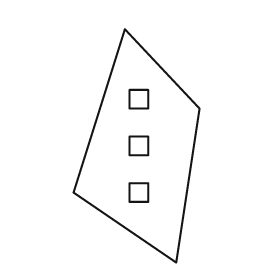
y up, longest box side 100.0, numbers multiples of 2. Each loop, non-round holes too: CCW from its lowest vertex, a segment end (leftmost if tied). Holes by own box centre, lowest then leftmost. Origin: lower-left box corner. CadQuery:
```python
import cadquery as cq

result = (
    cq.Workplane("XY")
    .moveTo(44.0, 0.0)
    .lineTo(54.0, 66.0)
    .lineTo(22.0, 100.0)
    .lineTo(0.0, 30.0)
    .close()
    .moveTo(24.0, 26.0)
    .lineTo(32.0, 26.0)
    .lineTo(32.0, 34.0)
    .lineTo(24.0, 34.0)
    .close()
    .moveTo(24.0, 46.0)
    .lineTo(32.0, 46.0)
    .lineTo(32.0, 54.0)
    .lineTo(24.0, 54.0)
    .close()
    .moveTo(24.0, 66.0)
    .lineTo(32.0, 66.0)
    .lineTo(32.0, 74.0)
    .lineTo(24.0, 74.0)
    .close()
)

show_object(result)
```